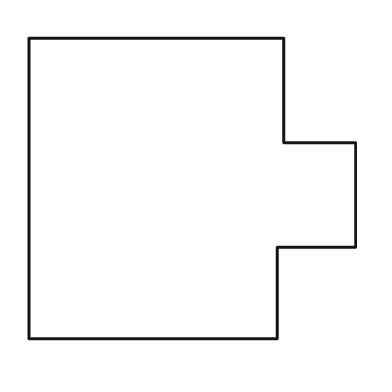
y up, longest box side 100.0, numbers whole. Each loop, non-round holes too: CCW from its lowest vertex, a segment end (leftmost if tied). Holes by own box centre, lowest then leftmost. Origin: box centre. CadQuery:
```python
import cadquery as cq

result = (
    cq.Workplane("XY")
    .moveTo(-50.0, -46.0)
    .lineTo(26.0, -46.0)
    .lineTo(26.0, -18.0)
    .lineTo(50.0, -18.0)
    .lineTo(50.0, 14.0)
    .lineTo(28.0, 14.0)
    .lineTo(28.0, 46.0)
    .lineTo(-50.0, 46.0)
    .close()
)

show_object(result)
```